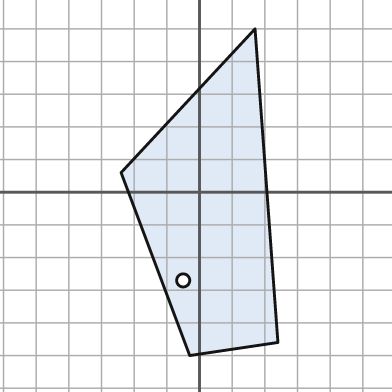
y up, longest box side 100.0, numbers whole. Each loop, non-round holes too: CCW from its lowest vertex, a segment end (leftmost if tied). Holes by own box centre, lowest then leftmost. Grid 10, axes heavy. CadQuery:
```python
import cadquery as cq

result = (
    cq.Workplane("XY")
    .moveTo(-3.0, -50.0)
    .lineTo(24.0, -46.0)
    .lineTo(17.0, 50.0)
    .lineTo(-24.0, 6.0)
    .close()
    .moveTo(-5.0, -27.0)
    .circle(2.0)
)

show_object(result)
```